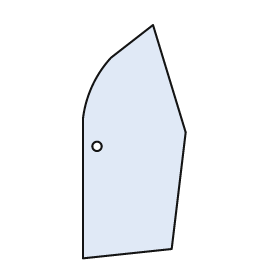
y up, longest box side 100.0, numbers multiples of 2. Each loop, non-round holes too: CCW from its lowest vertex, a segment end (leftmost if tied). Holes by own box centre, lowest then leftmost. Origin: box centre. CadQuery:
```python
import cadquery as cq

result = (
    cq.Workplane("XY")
    .moveTo(-22.0, -50.0)
    .lineTo(16.0, -46.0)
    .lineTo(22.0, 4.0)
    .lineTo(8.0, 50.0)
    .lineTo(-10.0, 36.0)
    .threePointArc((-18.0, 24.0), (-22.0, 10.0))
    .close()
    .moveTo(-16.0, -2.0)
    .circle(2.0)
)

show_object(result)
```